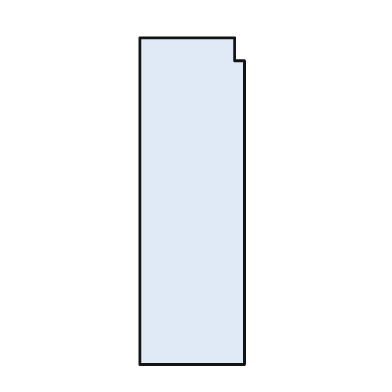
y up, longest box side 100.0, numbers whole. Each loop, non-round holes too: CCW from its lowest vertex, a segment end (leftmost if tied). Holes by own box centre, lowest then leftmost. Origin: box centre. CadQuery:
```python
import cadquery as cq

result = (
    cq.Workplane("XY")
    .moveTo(-16.0, -50.0)
    .lineTo(16.0, -50.0)
    .lineTo(16.0, 43.0)
    .lineTo(13.0, 43.0)
    .lineTo(13.0, 50.0)
    .lineTo(-16.0, 50.0)
    .close()
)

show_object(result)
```